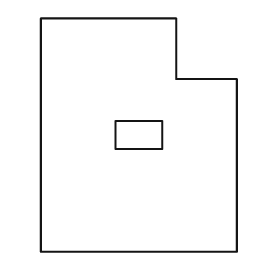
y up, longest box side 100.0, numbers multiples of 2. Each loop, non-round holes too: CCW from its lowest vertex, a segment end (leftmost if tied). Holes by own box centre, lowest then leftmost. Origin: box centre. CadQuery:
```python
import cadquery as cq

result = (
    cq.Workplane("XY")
    .moveTo(-42.0, -50.0)
    .lineTo(42.0, -50.0)
    .lineTo(42.0, 24.0)
    .lineTo(16.0, 24.0)
    .lineTo(16.0, 50.0)
    .lineTo(-42.0, 50.0)
    .close()
    .moveTo(-10.0, -6.0)
    .lineTo(10.0, -6.0)
    .lineTo(10.0, 6.0)
    .lineTo(-10.0, 6.0)
    .close()
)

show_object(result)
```